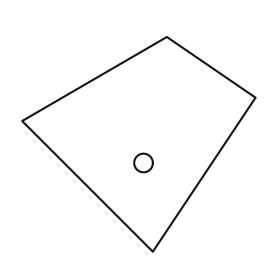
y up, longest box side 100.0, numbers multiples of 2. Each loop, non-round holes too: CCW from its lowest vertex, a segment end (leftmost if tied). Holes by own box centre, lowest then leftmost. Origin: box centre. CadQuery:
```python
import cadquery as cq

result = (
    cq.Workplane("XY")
    .moveTo(6.0, -46.0)
    .lineTo(50.0, 20.0)
    .lineTo(12.0, 46.0)
    .lineTo(-50.0, 10.0)
    .close()
    .moveTo(2.0, -8.0)
    .circle(4.0)
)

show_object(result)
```